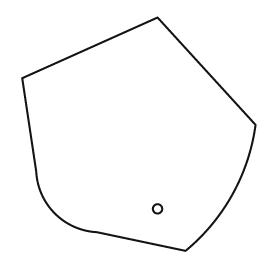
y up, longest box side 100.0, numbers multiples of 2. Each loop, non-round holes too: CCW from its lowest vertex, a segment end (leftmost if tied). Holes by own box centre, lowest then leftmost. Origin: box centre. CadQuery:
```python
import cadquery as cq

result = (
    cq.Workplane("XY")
    .moveTo(20.0, -50.0)
    .threePointArc((40.0, -26.0), (50.0, 4.0))
    .lineTo(8.0, 50.0)
    .lineTo(-50.0, 24.0)
    .lineTo(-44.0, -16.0)
    .threePointArc((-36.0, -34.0), (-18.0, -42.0))
    .close()
    .moveTo(8.0, -32.0)
    .circle(2.0)
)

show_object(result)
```